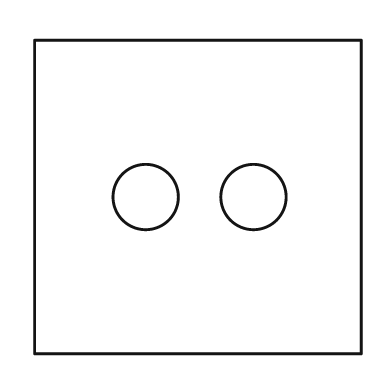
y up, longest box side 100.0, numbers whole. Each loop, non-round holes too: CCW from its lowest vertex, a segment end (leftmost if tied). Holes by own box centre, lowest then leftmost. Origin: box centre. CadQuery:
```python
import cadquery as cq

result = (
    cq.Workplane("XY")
    .moveTo(-50.0, -48.0)
    .lineTo(50.0, -48.0)
    .lineTo(50.0, 48.0)
    .lineTo(-50.0, 48.0)
    .close()
    .moveTo(-16.0, 0.0)
    .circle(10.0)
    .moveTo(17.0, 0.0)
    .circle(10.0)
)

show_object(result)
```